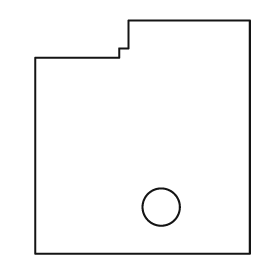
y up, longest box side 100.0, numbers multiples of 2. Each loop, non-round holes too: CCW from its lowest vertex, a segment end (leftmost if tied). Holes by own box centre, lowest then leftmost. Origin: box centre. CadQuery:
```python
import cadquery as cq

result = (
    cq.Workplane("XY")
    .moveTo(-46.0, -50.0)
    .lineTo(46.0, -50.0)
    .lineTo(46.0, 50.0)
    .lineTo(-6.0, 50.0)
    .lineTo(-6.0, 38.0)
    .lineTo(-10.0, 38.0)
    .lineTo(-10.0, 34.0)
    .lineTo(-46.0, 34.0)
    .close()
    .moveTo(8.0, -30.0)
    .circle(8.0)
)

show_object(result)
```